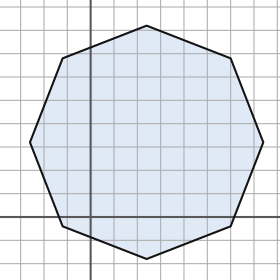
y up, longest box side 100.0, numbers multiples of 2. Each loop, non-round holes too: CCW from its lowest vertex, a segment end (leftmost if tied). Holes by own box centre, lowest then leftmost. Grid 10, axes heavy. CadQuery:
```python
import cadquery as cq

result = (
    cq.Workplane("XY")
    .moveTo(24.0, -18.0)
    .lineTo(60.0, -4.0)
    .lineTo(74.0, 32.0)
    .lineTo(60.0, 68.0)
    .lineTo(24.0, 82.0)
    .lineTo(-12.0, 68.0)
    .lineTo(-26.0, 32.0)
    .lineTo(-12.0, -4.0)
    .close()
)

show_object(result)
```